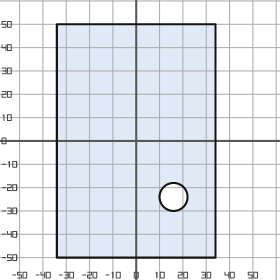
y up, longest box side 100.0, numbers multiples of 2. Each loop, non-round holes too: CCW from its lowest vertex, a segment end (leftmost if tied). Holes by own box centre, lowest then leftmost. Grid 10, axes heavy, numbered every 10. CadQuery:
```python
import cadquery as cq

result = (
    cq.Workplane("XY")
    .moveTo(-34.0, -50.0)
    .lineTo(34.0, -50.0)
    .lineTo(34.0, 50.0)
    .lineTo(-34.0, 50.0)
    .close()
    .moveTo(16.0, -24.0)
    .circle(6.0)
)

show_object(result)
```